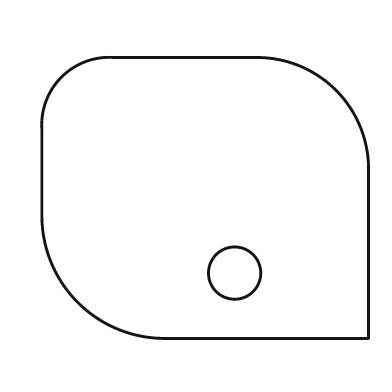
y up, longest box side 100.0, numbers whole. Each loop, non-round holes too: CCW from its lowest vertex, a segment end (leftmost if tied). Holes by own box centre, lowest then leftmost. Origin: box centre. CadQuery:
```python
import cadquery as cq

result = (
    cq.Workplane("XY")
    .moveTo(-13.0, -43.0)
    .lineTo(50.0, -43.0)
    .lineTo(50.0, 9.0)
    .threePointArc((40.0, 33.0), (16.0, 43.0))
    .lineTo(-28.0, 43.0)
    .threePointArc((-44.0, 37.0), (-50.0, 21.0))
    .lineTo(-50.0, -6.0)
    .threePointArc((-39.0, -32.0), (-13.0, -43.0))
    .close()
    .moveTo(9.0, -23.0)
    .circle(8.0)
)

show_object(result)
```